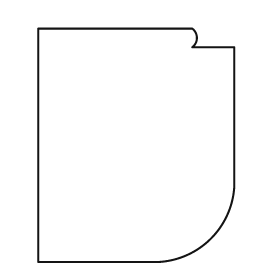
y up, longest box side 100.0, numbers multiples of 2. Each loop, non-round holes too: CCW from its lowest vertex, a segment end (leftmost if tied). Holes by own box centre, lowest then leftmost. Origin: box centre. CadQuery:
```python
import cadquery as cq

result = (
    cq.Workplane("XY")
    .moveTo(-42.0, -50.0)
    .lineTo(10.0, -50.0)
    .threePointArc((32.0, -40.0), (42.0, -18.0))
    .lineTo(42.0, 42.0)
    .lineTo(24.0, 42.0)
    .threePointArc((26.0, 46.0), (24.0, 50.0))
    .lineTo(-42.0, 50.0)
    .close()
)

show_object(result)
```